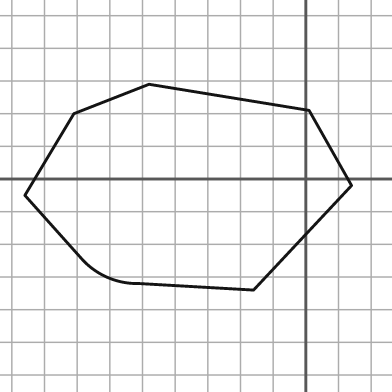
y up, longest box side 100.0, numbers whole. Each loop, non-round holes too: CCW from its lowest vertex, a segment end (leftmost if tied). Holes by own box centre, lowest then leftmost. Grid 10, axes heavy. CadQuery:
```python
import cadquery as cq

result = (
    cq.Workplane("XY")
    .moveTo(-16.0, -34.0)
    .lineTo(14.0, -2.0)
    .lineTo(1.0, 21.0)
    .lineTo(-48.0, 29.0)
    .lineTo(-71.0, 20.0)
    .lineTo(-86.0, -5.0)
    .lineTo(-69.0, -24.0)
    .threePointArc((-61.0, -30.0), (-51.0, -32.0))
    .close()
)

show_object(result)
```